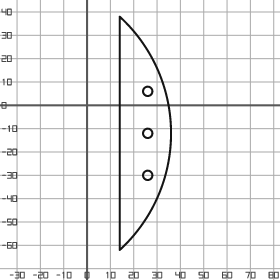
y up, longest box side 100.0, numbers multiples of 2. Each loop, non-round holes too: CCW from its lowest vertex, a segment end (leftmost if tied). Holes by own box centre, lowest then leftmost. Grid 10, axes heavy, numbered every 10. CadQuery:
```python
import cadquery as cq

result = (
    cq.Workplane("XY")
    .moveTo(14.0, -62.0)
    .threePointArc((36.0, -12.0), (14.0, 38.0))
    .close()
    .moveTo(26.0, -30.0)
    .circle(2.0)
    .moveTo(26.0, -12.0)
    .circle(2.0)
    .moveTo(26.0, 6.0)
    .circle(2.0)
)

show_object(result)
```